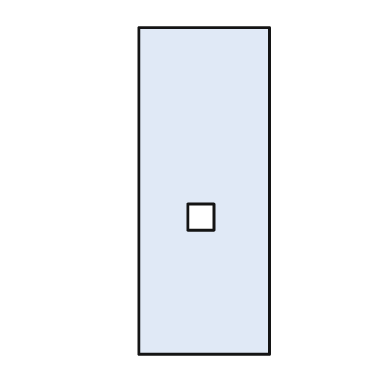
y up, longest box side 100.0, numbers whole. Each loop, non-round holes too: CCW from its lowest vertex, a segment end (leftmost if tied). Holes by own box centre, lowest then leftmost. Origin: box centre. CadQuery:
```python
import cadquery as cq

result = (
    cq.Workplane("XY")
    .moveTo(-20.0, -50.0)
    .lineTo(20.0, -50.0)
    .lineTo(20.0, 50.0)
    .lineTo(-20.0, 50.0)
    .close()
    .moveTo(-5.0, -12.0)
    .lineTo(3.0, -12.0)
    .lineTo(3.0, -4.0)
    .lineTo(-5.0, -4.0)
    .close()
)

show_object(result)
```